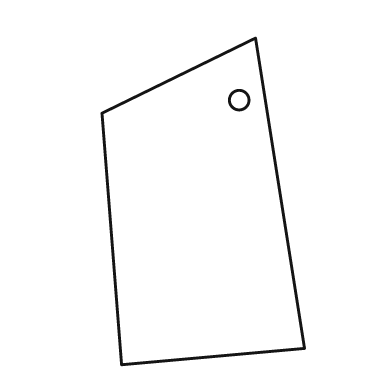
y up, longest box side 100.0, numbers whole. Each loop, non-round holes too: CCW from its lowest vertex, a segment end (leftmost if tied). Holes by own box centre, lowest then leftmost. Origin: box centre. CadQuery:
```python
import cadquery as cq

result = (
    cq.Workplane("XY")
    .moveTo(-25.0, -50.0)
    .lineTo(31.0, -45.0)
    .lineTo(16.0, 50.0)
    .lineTo(-31.0, 27.0)
    .close()
    .moveTo(11.0, 31.0)
    .circle(3.0)
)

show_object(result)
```